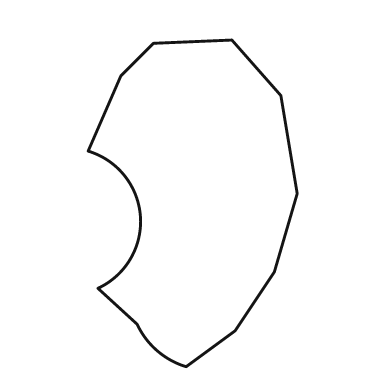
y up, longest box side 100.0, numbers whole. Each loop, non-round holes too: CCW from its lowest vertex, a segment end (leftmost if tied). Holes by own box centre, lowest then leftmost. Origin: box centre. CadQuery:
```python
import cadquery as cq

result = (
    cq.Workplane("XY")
    .moveTo(-2.0, -50.0)
    .lineTo(13.0, -39.0)
    .lineTo(25.0, -21.0)
    .lineTo(32.0, 3.0)
    .lineTo(27.0, 33.0)
    .lineTo(12.0, 50.0)
    .lineTo(-12.0, 49.0)
    .lineTo(-22.0, 39.0)
    .lineTo(-32.0, 16.0)
    .threePointArc((-16.0, -4.0), (-29.0, -26.0))
    .lineTo(-17.0, -37.0)
    .threePointArc((-11.0, -45.0), (-2.0, -50.0))
    .close()
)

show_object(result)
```